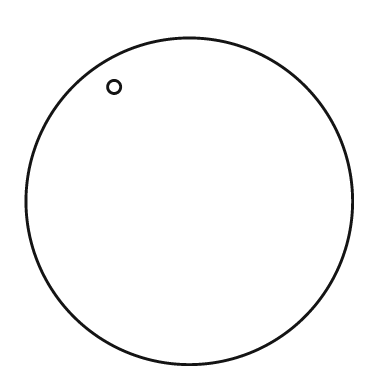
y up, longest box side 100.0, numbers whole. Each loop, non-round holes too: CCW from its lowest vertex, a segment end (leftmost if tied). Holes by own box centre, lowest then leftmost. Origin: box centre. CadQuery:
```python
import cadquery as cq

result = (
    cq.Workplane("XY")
    .moveTo(0.0, 0.0)
    .circle(50.0)
    .moveTo(-23.0, 35.0)
    .circle(2.0)
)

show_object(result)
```